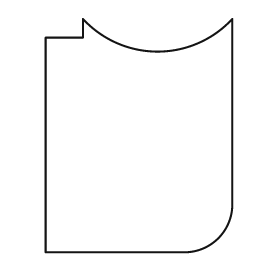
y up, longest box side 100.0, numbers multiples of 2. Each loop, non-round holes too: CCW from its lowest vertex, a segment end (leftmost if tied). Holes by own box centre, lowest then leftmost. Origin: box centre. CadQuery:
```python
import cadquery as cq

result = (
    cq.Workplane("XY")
    .moveTo(-40.0, -50.0)
    .lineTo(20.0, -50.0)
    .threePointArc((34.0, -44.0), (40.0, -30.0))
    .lineTo(40.0, 50.0)
    .threePointArc((8.0, 36.0), (-24.0, 50.0))
    .lineTo(-24.0, 42.0)
    .lineTo(-40.0, 42.0)
    .close()
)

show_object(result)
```